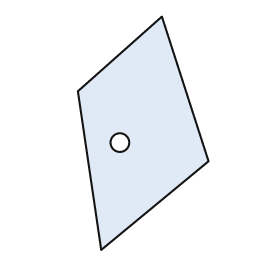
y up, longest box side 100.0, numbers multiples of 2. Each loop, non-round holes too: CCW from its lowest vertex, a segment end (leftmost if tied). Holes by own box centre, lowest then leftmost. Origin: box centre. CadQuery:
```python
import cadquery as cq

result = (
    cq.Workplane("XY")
    .moveTo(-18.0, -50.0)
    .lineTo(28.0, -12.0)
    .lineTo(8.0, 50.0)
    .lineTo(-28.0, 18.0)
    .close()
    .moveTo(-10.0, -4.0)
    .circle(4.0)
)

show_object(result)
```